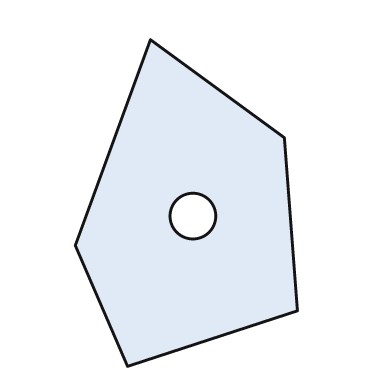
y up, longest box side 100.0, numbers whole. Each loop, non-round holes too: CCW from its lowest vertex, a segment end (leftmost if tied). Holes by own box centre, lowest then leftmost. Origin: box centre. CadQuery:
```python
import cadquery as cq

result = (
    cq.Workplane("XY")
    .moveTo(-18.0, -50.0)
    .lineTo(34.0, -33.0)
    .lineTo(30.0, 20.0)
    .lineTo(-11.0, 50.0)
    .lineTo(-34.0, -13.0)
    .close()
    .moveTo(2.0, -4.0)
    .circle(7.0)
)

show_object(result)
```